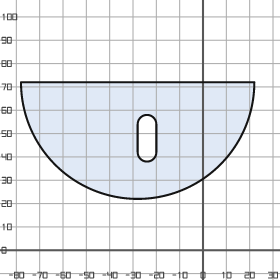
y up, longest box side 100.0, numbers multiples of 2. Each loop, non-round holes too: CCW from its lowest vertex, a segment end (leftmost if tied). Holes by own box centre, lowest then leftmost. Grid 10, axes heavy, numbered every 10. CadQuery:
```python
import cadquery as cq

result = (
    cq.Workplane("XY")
    .moveTo(-78.0, 72.0)
    .threePointArc((-28.0, 22.0), (22.0, 72.0))
    .close()
    .moveTo(-28.0, 42.0)
    .threePointArc((-24.0, 38.0), (-20.0, 42.0))
    .lineTo(-20.0, 54.0)
    .threePointArc((-24.0, 58.0), (-28.0, 54.0))
    .close()
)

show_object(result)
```